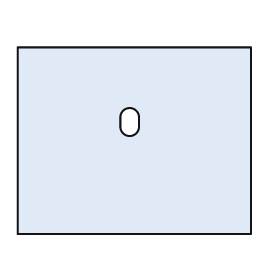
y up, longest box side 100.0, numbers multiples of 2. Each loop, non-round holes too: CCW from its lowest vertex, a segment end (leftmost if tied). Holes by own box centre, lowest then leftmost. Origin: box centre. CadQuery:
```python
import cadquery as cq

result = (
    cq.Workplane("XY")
    .moveTo(-50.0, -40.0)
    .lineTo(50.0, -40.0)
    .lineTo(50.0, 40.0)
    .lineTo(-50.0, 40.0)
    .close()
    .moveTo(-6.0, 6.0)
    .threePointArc((-2.0, 2.0), (2.0, 6.0))
    .lineTo(2.0, 10.0)
    .threePointArc((-2.0, 14.0), (-6.0, 10.0))
    .close()
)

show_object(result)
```